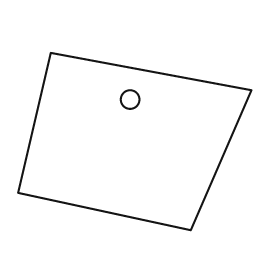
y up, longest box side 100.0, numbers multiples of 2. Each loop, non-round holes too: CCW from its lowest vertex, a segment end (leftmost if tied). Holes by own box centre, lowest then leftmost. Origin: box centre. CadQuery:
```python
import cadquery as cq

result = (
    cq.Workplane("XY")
    .moveTo(24.0, -38.0)
    .lineTo(50.0, 22.0)
    .lineTo(-36.0, 38.0)
    .lineTo(-50.0, -22.0)
    .close()
    .moveTo(-2.0, 18.0)
    .circle(4.0)
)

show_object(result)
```